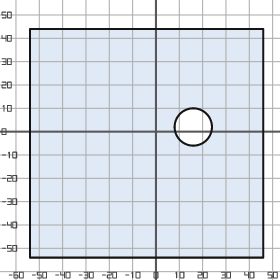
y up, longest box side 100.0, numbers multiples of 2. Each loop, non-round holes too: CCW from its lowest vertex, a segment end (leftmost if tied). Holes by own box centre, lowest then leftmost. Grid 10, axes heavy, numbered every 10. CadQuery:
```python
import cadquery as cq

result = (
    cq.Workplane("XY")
    .moveTo(-54.0, -54.0)
    .lineTo(46.0, -54.0)
    .lineTo(46.0, 44.0)
    .lineTo(-54.0, 44.0)
    .close()
    .moveTo(16.0, 2.0)
    .circle(8.0)
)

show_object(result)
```